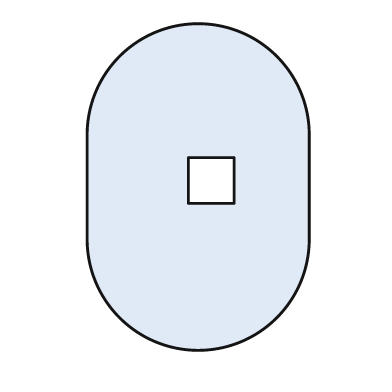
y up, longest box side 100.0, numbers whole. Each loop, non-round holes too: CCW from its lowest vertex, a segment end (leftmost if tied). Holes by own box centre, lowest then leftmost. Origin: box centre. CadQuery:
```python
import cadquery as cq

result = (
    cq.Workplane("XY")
    .moveTo(-34.0, -16.0)
    .threePointArc((0.0, -50.0), (34.0, -16.0))
    .lineTo(34.0, 16.0)
    .threePointArc((0.0, 50.0), (-34.0, 16.0))
    .close()
    .moveTo(-3.0, -5.0)
    .lineTo(11.0, -5.0)
    .lineTo(11.0, 9.0)
    .lineTo(-3.0, 9.0)
    .close()
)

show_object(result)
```